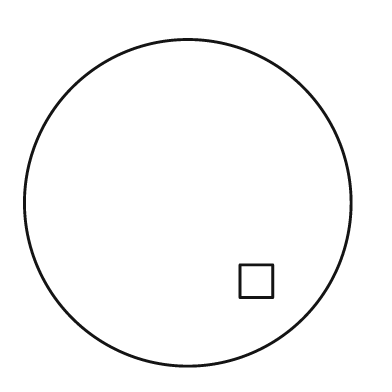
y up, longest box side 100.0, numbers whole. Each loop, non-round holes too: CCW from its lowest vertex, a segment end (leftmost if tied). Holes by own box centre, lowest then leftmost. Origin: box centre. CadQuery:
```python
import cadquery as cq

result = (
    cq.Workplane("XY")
    .moveTo(0.0, 0.0)
    .circle(50.0)
    .moveTo(16.0, -29.0)
    .lineTo(26.0, -29.0)
    .lineTo(26.0, -19.0)
    .lineTo(16.0, -19.0)
    .close()
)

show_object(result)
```